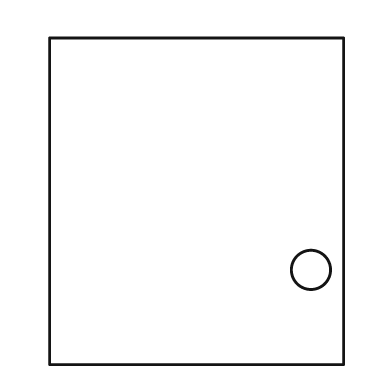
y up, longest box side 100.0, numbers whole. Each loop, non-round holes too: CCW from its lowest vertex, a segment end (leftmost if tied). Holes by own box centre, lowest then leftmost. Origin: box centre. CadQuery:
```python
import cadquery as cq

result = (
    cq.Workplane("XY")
    .moveTo(-45.0, -50.0)
    .lineTo(45.0, -50.0)
    .lineTo(45.0, 50.0)
    .lineTo(-45.0, 50.0)
    .close()
    .moveTo(35.0, -21.0)
    .circle(6.0)
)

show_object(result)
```